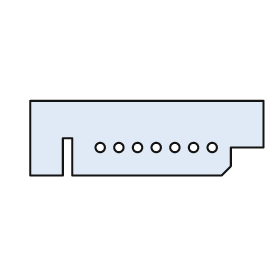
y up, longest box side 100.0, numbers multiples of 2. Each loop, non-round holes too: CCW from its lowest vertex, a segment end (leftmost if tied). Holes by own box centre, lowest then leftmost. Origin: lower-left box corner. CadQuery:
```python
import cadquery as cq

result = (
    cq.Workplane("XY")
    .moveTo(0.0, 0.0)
    .lineTo(14.0, 0.0)
    .lineTo(14.0, 16.0)
    .lineTo(18.0, 16.0)
    .lineTo(18.0, 0.0)
    .lineTo(82.0, 0.0)
    .lineTo(86.0, 4.0)
    .lineTo(86.0, 12.0)
    .lineTo(100.0, 12.0)
    .lineTo(100.0, 32.0)
    .lineTo(0.0, 32.0)
    .close()
    .moveTo(30.0, 12.0)
    .circle(2.0)
    .moveTo(38.0, 12.0)
    .circle(2.0)
    .moveTo(46.0, 12.0)
    .circle(2.0)
    .moveTo(54.0, 12.0)
    .circle(2.0)
    .moveTo(62.0, 12.0)
    .circle(2.0)
    .moveTo(70.0, 12.0)
    .circle(2.0)
    .moveTo(78.0, 12.0)
    .circle(2.0)
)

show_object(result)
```